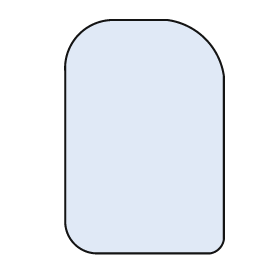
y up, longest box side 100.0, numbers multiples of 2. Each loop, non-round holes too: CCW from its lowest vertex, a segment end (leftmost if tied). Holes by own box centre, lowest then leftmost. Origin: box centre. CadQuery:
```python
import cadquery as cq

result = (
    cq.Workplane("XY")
    .moveTo(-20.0, -50.0)
    .lineTo(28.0, -50.0)
    .threePointArc((32.0, -48.0), (34.0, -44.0))
    .lineTo(34.0, 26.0)
    .threePointArc((26.0, 42.0), (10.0, 50.0))
    .lineTo(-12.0, 50.0)
    .threePointArc((-28.0, 44.0), (-34.0, 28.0))
    .lineTo(-34.0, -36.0)
    .threePointArc((-30.0, -46.0), (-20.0, -50.0))
    .close()
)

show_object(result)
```